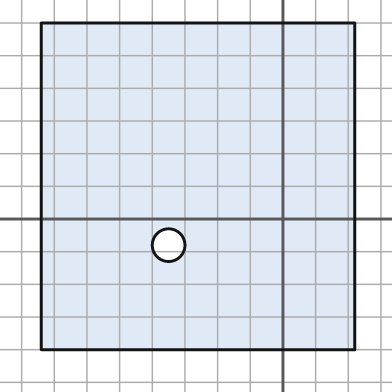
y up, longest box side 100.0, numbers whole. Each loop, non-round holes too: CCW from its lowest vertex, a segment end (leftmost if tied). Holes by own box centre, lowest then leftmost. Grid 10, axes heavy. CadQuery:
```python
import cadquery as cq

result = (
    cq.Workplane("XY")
    .moveTo(-74.0, -40.0)
    .lineTo(22.0, -40.0)
    .lineTo(22.0, 60.0)
    .lineTo(-74.0, 60.0)
    .close()
    .moveTo(-35.0, -8.0)
    .circle(5.0)
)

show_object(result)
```